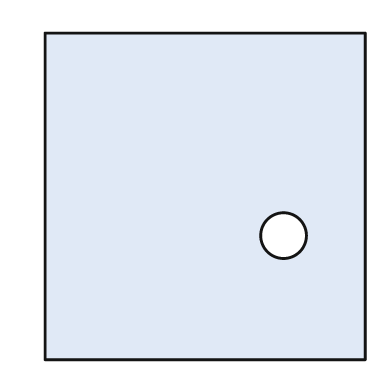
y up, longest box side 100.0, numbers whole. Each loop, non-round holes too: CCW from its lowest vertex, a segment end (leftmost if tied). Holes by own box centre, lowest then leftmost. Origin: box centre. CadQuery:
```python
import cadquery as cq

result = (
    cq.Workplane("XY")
    .moveTo(-49.0, -50.0)
    .lineTo(49.0, -50.0)
    .lineTo(49.0, 50.0)
    .lineTo(-49.0, 50.0)
    .close()
    .moveTo(24.0, -12.0)
    .circle(7.0)
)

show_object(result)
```